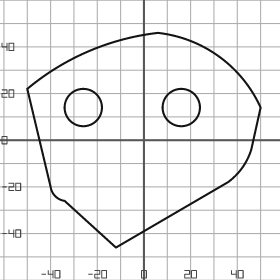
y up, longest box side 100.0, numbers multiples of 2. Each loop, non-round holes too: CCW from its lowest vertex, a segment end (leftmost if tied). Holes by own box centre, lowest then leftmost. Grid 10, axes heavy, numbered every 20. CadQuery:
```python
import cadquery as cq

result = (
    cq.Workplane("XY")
    .moveTo(-12.0, -46.0)
    .lineTo(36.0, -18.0)
    .threePointArc((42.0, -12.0), (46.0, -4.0))
    .lineTo(50.0, 14.0)
    .threePointArc((32.0, 36.0), (6.0, 46.0))
    .threePointArc((-24.0, 38.0), (-50.0, 22.0))
    .lineTo(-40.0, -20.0)
    .threePointArc((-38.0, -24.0), (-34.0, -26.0))
    .close()
    .moveTo(-26.0, 14.0)
    .circle(8.0)
    .moveTo(16.0, 14.0)
    .circle(8.0)
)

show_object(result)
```